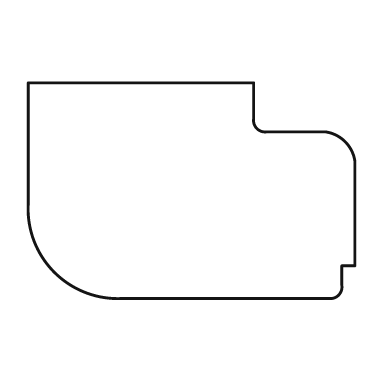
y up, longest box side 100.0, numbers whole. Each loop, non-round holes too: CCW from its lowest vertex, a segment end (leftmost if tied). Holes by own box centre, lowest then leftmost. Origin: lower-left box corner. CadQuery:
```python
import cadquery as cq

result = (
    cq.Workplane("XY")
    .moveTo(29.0, 0.0)
    .lineTo(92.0, 0.0)
    .threePointArc((95.0, 1.0), (96.0, 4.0))
    .lineTo(96.0, 10.0)
    .lineTo(100.0, 10.0)
    .lineTo(100.0, 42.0)
    .threePointArc((97.0, 48.0), (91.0, 51.0))
    .lineTo(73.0, 51.0)
    .threePointArc((70.0, 52.0), (69.0, 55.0))
    .lineTo(69.0, 66.0)
    .lineTo(0.0, 66.0)
    .lineTo(0.0, 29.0)
    .threePointArc((8.0, 8.0), (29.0, 0.0))
    .close()
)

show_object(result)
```